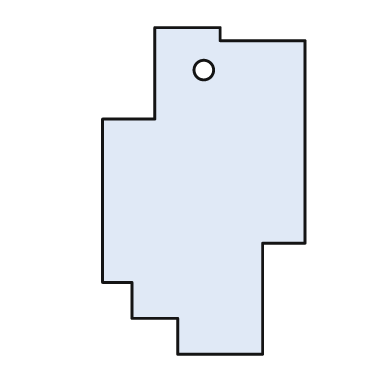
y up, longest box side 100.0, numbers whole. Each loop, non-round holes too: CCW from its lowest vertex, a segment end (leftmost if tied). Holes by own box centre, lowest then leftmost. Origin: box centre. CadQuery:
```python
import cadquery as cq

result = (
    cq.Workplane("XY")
    .moveTo(-8.0, -50.0)
    .lineTo(18.0, -50.0)
    .lineTo(18.0, -16.0)
    .lineTo(31.0, -16.0)
    .lineTo(31.0, 46.0)
    .lineTo(5.0, 46.0)
    .lineTo(5.0, 50.0)
    .lineTo(-15.0, 50.0)
    .lineTo(-15.0, 22.0)
    .lineTo(-31.0, 22.0)
    .lineTo(-31.0, -28.0)
    .lineTo(-22.0, -28.0)
    .lineTo(-22.0, -39.0)
    .lineTo(-8.0, -39.0)
    .close()
    .moveTo(0.0, 37.0)
    .circle(3.0)
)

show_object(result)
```